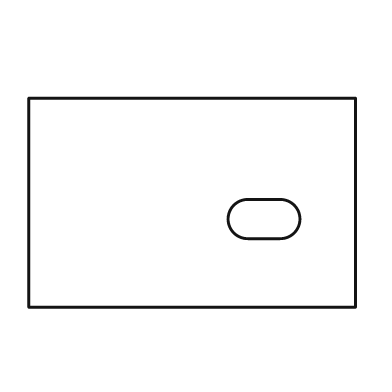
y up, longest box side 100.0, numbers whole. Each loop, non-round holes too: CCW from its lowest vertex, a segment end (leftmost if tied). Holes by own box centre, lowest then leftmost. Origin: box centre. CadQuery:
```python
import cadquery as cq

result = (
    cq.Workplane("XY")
    .moveTo(-50.0, -32.0)
    .lineTo(50.0, -32.0)
    .lineTo(50.0, 32.0)
    .lineTo(-50.0, 32.0)
    .close()
    .moveTo(17.0, -11.0)
    .lineTo(27.0, -11.0)
    .threePointArc((33.0, -5.0), (27.0, 1.0))
    .lineTo(17.0, 1.0)
    .threePointArc((11.0, -5.0), (17.0, -11.0))
    .close()
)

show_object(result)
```